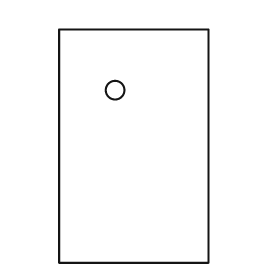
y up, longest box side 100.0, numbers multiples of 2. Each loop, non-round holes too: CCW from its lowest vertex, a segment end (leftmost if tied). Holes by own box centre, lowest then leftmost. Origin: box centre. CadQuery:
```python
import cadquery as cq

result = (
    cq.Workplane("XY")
    .moveTo(-32.0, -50.0)
    .lineTo(32.0, -50.0)
    .lineTo(32.0, 50.0)
    .lineTo(-32.0, 50.0)
    .close()
    .moveTo(-8.0, 24.0)
    .circle(4.0)
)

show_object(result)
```